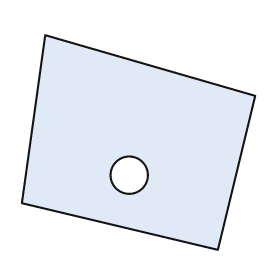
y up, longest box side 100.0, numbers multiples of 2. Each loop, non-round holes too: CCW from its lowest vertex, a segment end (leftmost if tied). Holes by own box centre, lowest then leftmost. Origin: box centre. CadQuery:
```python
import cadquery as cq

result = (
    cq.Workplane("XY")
    .moveTo(34.0, -46.0)
    .lineTo(50.0, 20.0)
    .lineTo(-40.0, 46.0)
    .lineTo(-50.0, -26.0)
    .close()
    .moveTo(-4.0, -14.0)
    .circle(8.0)
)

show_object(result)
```